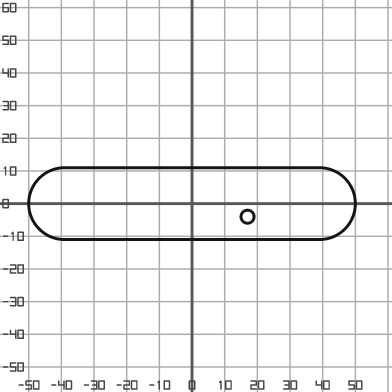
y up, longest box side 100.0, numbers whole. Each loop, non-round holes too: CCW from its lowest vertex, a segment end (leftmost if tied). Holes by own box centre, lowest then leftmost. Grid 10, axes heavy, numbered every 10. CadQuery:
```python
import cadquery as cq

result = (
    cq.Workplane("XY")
    .moveTo(-39.0, -11.0)
    .lineTo(39.0, -11.0)
    .threePointArc((50.0, 0.0), (39.0, 11.0))
    .lineTo(-39.0, 11.0)
    .threePointArc((-50.0, 0.0), (-39.0, -11.0))
    .close()
    .moveTo(17.0, -4.0)
    .circle(2.0)
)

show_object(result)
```